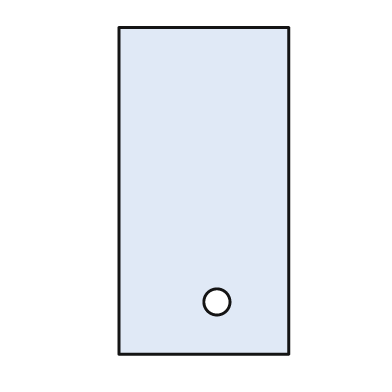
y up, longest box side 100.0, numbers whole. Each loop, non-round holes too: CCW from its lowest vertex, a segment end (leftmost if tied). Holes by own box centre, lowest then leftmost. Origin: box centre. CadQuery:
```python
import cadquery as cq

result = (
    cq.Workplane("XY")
    .moveTo(-26.0, -50.0)
    .lineTo(26.0, -50.0)
    .lineTo(26.0, 50.0)
    .lineTo(-26.0, 50.0)
    .close()
    .moveTo(4.0, -34.0)
    .circle(4.0)
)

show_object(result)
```